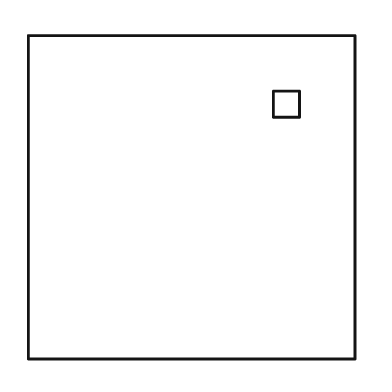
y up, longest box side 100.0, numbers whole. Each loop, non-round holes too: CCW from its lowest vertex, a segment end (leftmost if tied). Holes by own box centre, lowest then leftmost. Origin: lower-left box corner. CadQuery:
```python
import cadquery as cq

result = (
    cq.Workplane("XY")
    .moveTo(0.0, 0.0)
    .lineTo(100.0, 0.0)
    .lineTo(100.0, 99.0)
    .lineTo(0.0, 99.0)
    .close()
    .moveTo(75.0, 74.0)
    .lineTo(83.0, 74.0)
    .lineTo(83.0, 82.0)
    .lineTo(75.0, 82.0)
    .close()
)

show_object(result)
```